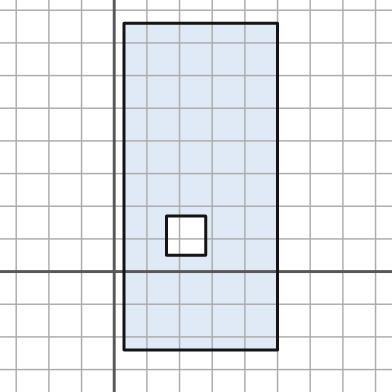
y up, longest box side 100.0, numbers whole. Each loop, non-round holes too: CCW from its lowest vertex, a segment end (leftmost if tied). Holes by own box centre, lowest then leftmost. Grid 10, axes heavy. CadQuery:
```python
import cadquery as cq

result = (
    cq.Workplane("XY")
    .moveTo(3.0, -24.0)
    .lineTo(50.0, -24.0)
    .lineTo(50.0, 76.0)
    .lineTo(3.0, 76.0)
    .close()
    .moveTo(16.0, 5.0)
    .lineTo(28.0, 5.0)
    .lineTo(28.0, 17.0)
    .lineTo(16.0, 17.0)
    .close()
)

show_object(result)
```